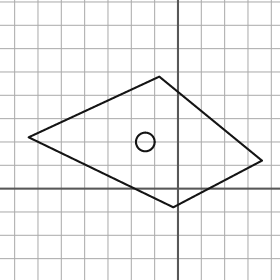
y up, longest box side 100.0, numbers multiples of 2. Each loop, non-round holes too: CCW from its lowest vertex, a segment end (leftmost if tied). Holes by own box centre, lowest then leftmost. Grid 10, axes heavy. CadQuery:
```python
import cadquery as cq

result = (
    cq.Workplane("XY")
    .moveTo(-2.0, -8.0)
    .lineTo(36.0, 12.0)
    .lineTo(-8.0, 48.0)
    .lineTo(-64.0, 22.0)
    .close()
    .moveTo(-14.0, 20.0)
    .circle(4.0)
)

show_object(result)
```